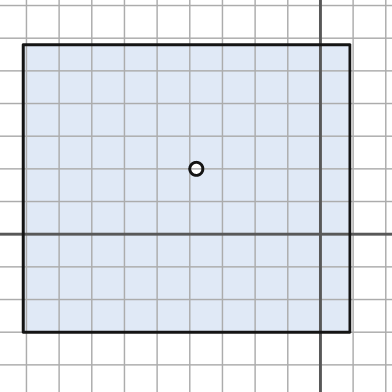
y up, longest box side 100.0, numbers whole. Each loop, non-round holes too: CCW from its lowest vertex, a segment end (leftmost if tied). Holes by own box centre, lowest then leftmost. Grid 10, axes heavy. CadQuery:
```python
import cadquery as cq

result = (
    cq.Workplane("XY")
    .moveTo(-91.0, -30.0)
    .lineTo(9.0, -30.0)
    .lineTo(9.0, 58.0)
    .lineTo(-91.0, 58.0)
    .close()
    .moveTo(-38.0, 20.0)
    .circle(2.0)
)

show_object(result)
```